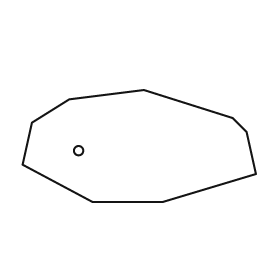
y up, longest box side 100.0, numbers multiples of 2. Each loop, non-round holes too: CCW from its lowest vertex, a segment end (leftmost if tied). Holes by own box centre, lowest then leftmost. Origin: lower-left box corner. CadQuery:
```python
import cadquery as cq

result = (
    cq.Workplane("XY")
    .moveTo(30.0, 0.0)
    .lineTo(60.0, 0.0)
    .lineTo(100.0, 12.0)
    .lineTo(96.0, 30.0)
    .lineTo(90.0, 36.0)
    .lineTo(52.0, 48.0)
    .lineTo(20.0, 44.0)
    .lineTo(4.0, 34.0)
    .lineTo(0.0, 16.0)
    .close()
    .moveTo(24.0, 22.0)
    .circle(2.0)
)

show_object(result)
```